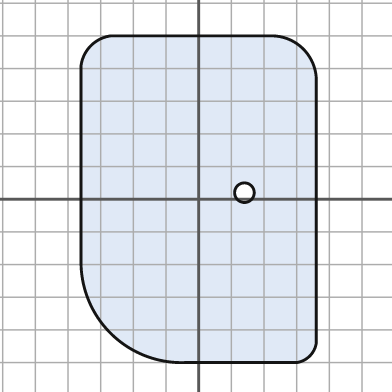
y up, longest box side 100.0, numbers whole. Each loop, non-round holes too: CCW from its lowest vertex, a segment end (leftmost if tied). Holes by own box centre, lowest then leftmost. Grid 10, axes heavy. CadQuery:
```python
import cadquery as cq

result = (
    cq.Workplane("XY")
    .moveTo(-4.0, -50.0)
    .lineTo(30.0, -50.0)
    .threePointArc((34.0, -48.0), (36.0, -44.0))
    .lineTo(36.0, 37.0)
    .threePointArc((32.0, 46.0), (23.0, 50.0))
    .lineTo(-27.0, 50.0)
    .threePointArc((-33.0, 47.0), (-36.0, 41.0))
    .lineTo(-36.0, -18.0)
    .threePointArc((-27.0, -41.0), (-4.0, -50.0))
    .close()
    .moveTo(14.0, 2.0)
    .circle(3.0)
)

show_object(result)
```